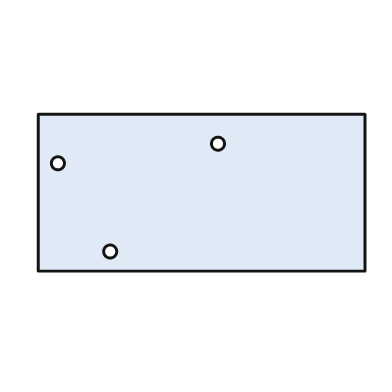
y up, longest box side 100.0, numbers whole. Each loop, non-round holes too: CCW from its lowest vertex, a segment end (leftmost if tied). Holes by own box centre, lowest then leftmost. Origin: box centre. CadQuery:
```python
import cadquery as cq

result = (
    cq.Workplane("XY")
    .moveTo(-50.0, -24.0)
    .lineTo(50.0, -24.0)
    .lineTo(50.0, 24.0)
    .lineTo(-50.0, 24.0)
    .close()
    .moveTo(-28.0, -18.0)
    .circle(2.0)
    .moveTo(-44.0, 9.0)
    .circle(2.0)
    .moveTo(5.0, 15.0)
    .circle(2.0)
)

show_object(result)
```